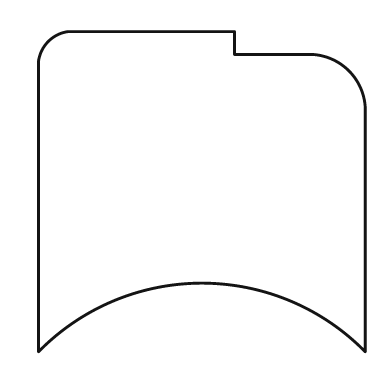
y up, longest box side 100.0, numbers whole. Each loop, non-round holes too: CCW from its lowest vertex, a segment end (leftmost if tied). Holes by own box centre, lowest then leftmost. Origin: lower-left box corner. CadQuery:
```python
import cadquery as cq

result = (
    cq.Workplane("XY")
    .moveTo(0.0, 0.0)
    .threePointArc((50.0, 21.0), (100.0, 0.0))
    .lineTo(100.0, 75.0)
    .threePointArc((95.0, 86.0), (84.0, 91.0))
    .lineTo(60.0, 91.0)
    .lineTo(60.0, 98.0)
    .lineTo(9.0, 98.0)
    .threePointArc((3.0, 95.0), (0.0, 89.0))
    .close()
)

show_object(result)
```